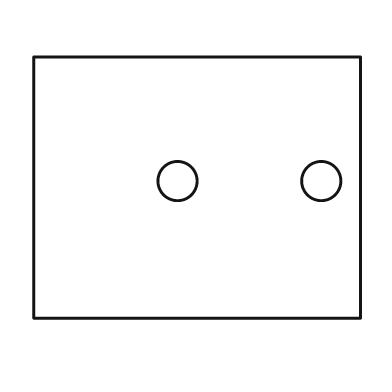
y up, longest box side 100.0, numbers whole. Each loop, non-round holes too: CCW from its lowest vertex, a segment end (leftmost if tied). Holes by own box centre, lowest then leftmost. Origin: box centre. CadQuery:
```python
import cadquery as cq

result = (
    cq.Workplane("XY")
    .moveTo(-50.0, -40.0)
    .lineTo(50.0, -40.0)
    .lineTo(50.0, 40.0)
    .lineTo(-50.0, 40.0)
    .close()
    .moveTo(-6.0, 2.0)
    .circle(6.0)
    .moveTo(38.0, 2.0)
    .circle(6.0)
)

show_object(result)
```